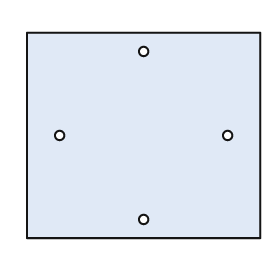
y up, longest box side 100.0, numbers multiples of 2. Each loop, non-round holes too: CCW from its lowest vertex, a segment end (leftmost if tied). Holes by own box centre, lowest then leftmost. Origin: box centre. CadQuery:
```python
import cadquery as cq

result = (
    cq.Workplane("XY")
    .moveTo(-50.0, -44.0)
    .lineTo(50.0, -44.0)
    .lineTo(50.0, 44.0)
    .lineTo(-50.0, 44.0)
    .close()
    .moveTo(0.0, -36.0)
    .circle(2.0)
    .moveTo(-36.0, 0.0)
    .circle(2.0)
    .moveTo(36.0, 0.0)
    .circle(2.0)
    .moveTo(0.0, 36.0)
    .circle(2.0)
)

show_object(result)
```